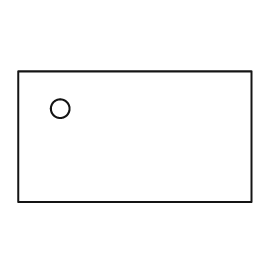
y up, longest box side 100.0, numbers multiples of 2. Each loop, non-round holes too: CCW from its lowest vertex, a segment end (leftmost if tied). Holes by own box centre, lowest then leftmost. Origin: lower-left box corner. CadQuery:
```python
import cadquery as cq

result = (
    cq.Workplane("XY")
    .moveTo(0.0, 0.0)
    .lineTo(100.0, 0.0)
    .lineTo(100.0, 56.0)
    .lineTo(0.0, 56.0)
    .close()
    .moveTo(18.0, 40.0)
    .circle(4.0)
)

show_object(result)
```